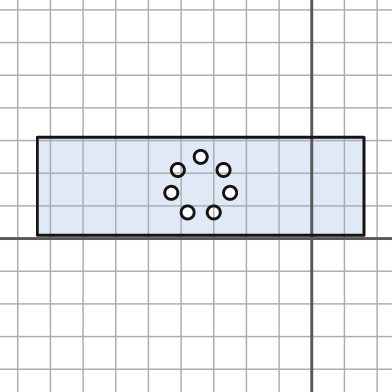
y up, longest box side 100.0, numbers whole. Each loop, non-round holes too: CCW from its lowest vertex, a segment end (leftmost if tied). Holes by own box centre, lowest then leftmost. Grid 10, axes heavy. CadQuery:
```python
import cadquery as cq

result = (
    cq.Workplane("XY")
    .moveTo(-84.0, 1.0)
    .lineTo(16.0, 1.0)
    .lineTo(16.0, 31.0)
    .lineTo(-84.0, 31.0)
    .close()
    .moveTo(-38.0, 8.0)
    .circle(2.0)
    .moveTo(-30.0, 8.0)
    .circle(2.0)
    .moveTo(-43.0, 14.0)
    .circle(2.0)
    .moveTo(-25.0, 14.0)
    .circle(2.0)
    .moveTo(-41.0, 21.0)
    .circle(2.0)
    .moveTo(-27.0, 21.0)
    .circle(2.0)
    .moveTo(-34.0, 25.0)
    .circle(2.0)
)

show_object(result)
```